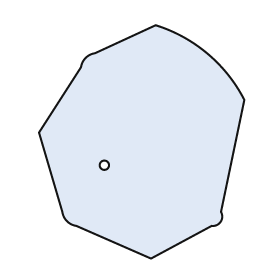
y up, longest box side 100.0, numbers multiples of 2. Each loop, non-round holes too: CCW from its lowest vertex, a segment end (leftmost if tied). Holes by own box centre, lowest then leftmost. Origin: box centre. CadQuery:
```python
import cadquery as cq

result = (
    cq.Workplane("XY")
    .moveTo(4.0, -50.0)
    .lineTo(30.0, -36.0)
    .threePointArc((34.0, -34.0), (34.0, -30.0))
    .lineTo(44.0, 18.0)
    .threePointArc((28.0, 38.0), (6.0, 50.0))
    .lineTo(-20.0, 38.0)
    .threePointArc((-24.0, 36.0), (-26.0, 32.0))
    .lineTo(-44.0, 4.0)
    .lineTo(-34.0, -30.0)
    .threePointArc((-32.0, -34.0), (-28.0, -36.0))
    .close()
    .moveTo(-16.0, -10.0)
    .circle(2.0)
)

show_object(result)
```